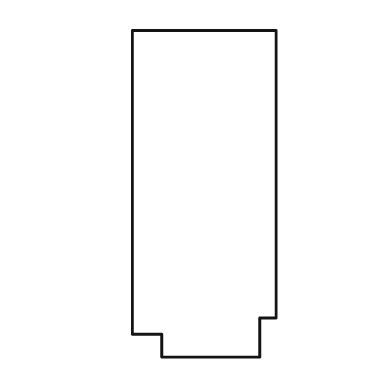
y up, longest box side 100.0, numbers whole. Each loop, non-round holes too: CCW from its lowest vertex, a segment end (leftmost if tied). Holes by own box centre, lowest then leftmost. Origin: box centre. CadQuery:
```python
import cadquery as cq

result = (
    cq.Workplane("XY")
    .moveTo(-13.0, -50.0)
    .lineTo(17.0, -50.0)
    .lineTo(17.0, -38.0)
    .lineTo(22.0, -38.0)
    .lineTo(22.0, 50.0)
    .lineTo(-22.0, 50.0)
    .lineTo(-22.0, -43.0)
    .lineTo(-13.0, -43.0)
    .close()
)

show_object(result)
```